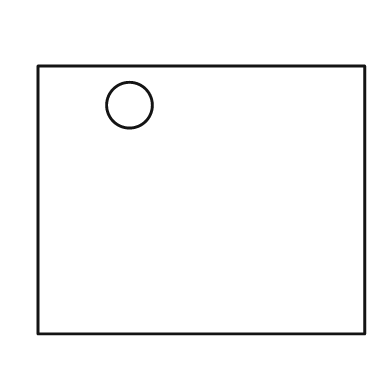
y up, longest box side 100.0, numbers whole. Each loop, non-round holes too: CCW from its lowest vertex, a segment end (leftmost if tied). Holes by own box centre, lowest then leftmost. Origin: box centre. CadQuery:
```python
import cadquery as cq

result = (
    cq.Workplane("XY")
    .moveTo(-50.0, -41.0)
    .lineTo(50.0, -41.0)
    .lineTo(50.0, 41.0)
    .lineTo(-50.0, 41.0)
    .close()
    .moveTo(-22.0, 29.0)
    .circle(7.0)
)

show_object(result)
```